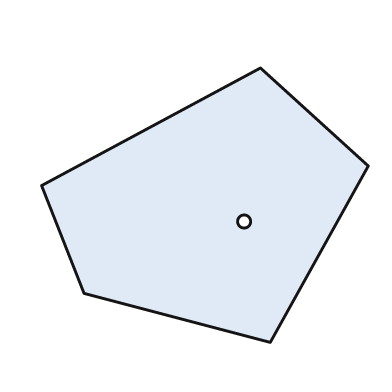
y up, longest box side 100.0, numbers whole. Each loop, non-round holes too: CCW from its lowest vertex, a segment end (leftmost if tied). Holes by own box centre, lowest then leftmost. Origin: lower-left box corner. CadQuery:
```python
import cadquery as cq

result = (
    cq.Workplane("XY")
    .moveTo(70.0, 0.0)
    .lineTo(100.0, 54.0)
    .lineTo(67.0, 84.0)
    .lineTo(0.0, 48.0)
    .lineTo(13.0, 15.0)
    .close()
    .moveTo(62.0, 37.0)
    .circle(2.0)
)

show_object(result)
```